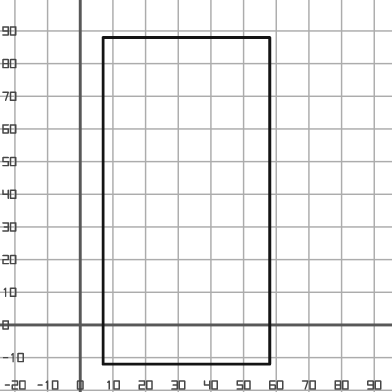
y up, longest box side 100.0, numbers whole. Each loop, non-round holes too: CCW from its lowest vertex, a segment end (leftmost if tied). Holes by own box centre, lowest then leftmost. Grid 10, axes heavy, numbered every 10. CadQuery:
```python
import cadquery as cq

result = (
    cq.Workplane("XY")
    .moveTo(7.0, -12.0)
    .lineTo(58.0, -12.0)
    .lineTo(58.0, 88.0)
    .lineTo(7.0, 88.0)
    .close()
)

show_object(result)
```